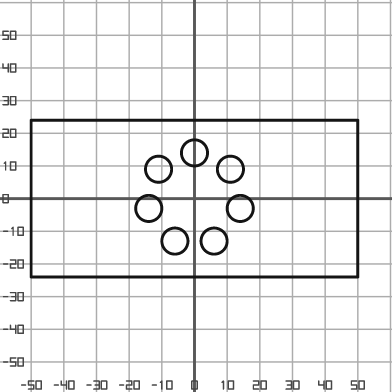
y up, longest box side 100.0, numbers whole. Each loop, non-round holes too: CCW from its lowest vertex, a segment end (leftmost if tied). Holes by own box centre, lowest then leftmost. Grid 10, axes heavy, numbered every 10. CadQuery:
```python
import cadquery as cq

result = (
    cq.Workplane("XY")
    .moveTo(-50.0, -24.0)
    .lineTo(50.0, -24.0)
    .lineTo(50.0, 24.0)
    .lineTo(-50.0, 24.0)
    .close()
    .moveTo(-6.0, -13.0)
    .circle(4.0)
    .moveTo(6.0, -13.0)
    .circle(4.0)
    .moveTo(-14.0, -3.0)
    .circle(4.0)
    .moveTo(14.0, -3.0)
    .circle(4.0)
    .moveTo(-11.0, 9.0)
    .circle(4.0)
    .moveTo(11.0, 9.0)
    .circle(4.0)
    .moveTo(0.0, 14.0)
    .circle(4.0)
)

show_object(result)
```